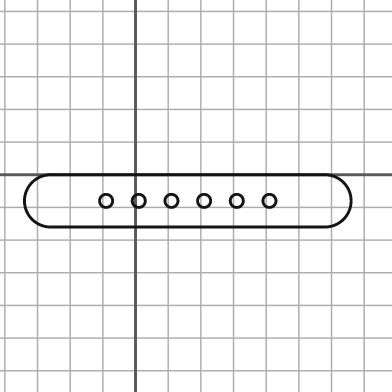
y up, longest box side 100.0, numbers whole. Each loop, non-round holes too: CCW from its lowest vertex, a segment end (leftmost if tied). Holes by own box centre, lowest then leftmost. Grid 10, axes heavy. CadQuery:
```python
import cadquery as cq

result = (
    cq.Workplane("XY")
    .moveTo(-26.0, -16.0)
    .lineTo(58.0, -16.0)
    .threePointArc((66.0, -8.0), (58.0, 0.0))
    .lineTo(-26.0, 0.0)
    .threePointArc((-34.0, -8.0), (-26.0, -16.0))
    .close()
    .moveTo(-9.0, -8.0)
    .circle(2.0)
    .moveTo(1.0, -8.0)
    .circle(2.0)
    .moveTo(11.0, -8.0)
    .circle(2.0)
    .moveTo(21.0, -8.0)
    .circle(2.0)
    .moveTo(31.0, -8.0)
    .circle(2.0)
    .moveTo(41.0, -8.0)
    .circle(2.0)
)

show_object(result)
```